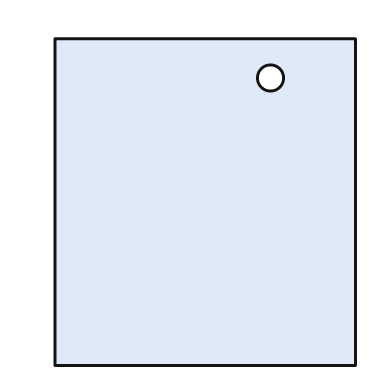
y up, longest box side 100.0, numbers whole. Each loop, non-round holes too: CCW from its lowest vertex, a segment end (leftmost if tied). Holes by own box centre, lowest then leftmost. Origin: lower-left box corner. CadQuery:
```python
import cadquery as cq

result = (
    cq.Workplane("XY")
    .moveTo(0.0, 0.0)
    .lineTo(92.0, 0.0)
    .lineTo(92.0, 100.0)
    .lineTo(0.0, 100.0)
    .close()
    .moveTo(66.0, 88.0)
    .circle(4.0)
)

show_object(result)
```